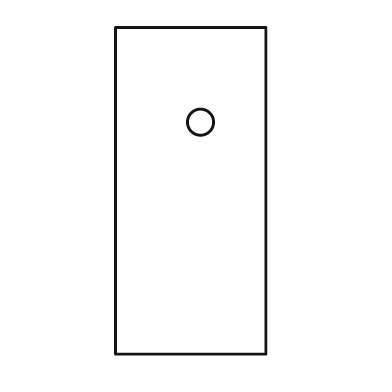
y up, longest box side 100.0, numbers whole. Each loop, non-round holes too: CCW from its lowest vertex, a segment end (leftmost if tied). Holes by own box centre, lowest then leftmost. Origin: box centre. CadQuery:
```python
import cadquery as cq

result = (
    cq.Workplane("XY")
    .moveTo(-23.0, -50.0)
    .lineTo(23.0, -50.0)
    .lineTo(23.0, 50.0)
    .lineTo(-23.0, 50.0)
    .close()
    .moveTo(3.0, 21.0)
    .circle(4.0)
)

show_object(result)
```